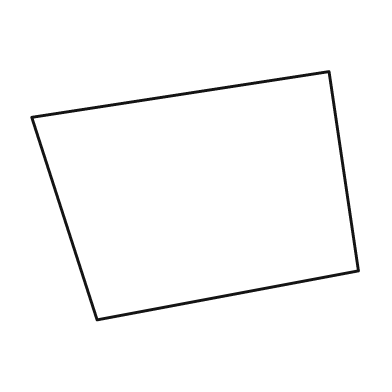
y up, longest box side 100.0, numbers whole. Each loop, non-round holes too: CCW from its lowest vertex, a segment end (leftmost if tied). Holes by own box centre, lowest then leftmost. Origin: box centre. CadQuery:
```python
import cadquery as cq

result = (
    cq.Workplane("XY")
    .moveTo(-30.0, -38.0)
    .lineTo(50.0, -23.0)
    .lineTo(41.0, 38.0)
    .lineTo(-50.0, 24.0)
    .close()
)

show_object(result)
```